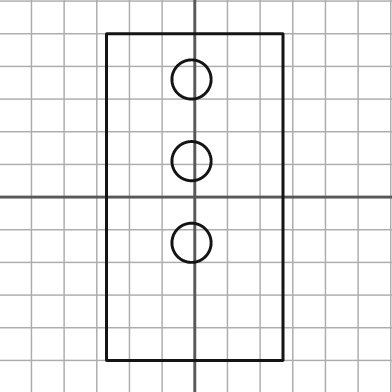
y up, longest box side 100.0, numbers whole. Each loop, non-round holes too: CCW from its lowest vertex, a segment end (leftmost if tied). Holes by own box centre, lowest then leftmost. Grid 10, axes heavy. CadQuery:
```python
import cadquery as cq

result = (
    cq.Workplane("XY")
    .moveTo(-27.0, -50.0)
    .lineTo(27.0, -50.0)
    .lineTo(27.0, 50.0)
    .lineTo(-27.0, 50.0)
    .close()
    .moveTo(-1.0, -14.0)
    .circle(6.0)
    .moveTo(-1.0, 11.0)
    .circle(6.0)
    .moveTo(-1.0, 36.0)
    .circle(6.0)
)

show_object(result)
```